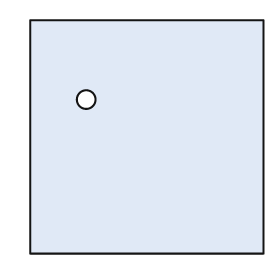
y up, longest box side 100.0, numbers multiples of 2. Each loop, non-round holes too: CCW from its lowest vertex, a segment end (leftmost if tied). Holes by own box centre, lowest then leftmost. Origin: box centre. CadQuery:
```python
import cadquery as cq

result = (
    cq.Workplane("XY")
    .moveTo(-50.0, -50.0)
    .lineTo(50.0, -50.0)
    .lineTo(50.0, 50.0)
    .lineTo(-50.0, 50.0)
    .close()
    .moveTo(-26.0, 16.0)
    .circle(4.0)
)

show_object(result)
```